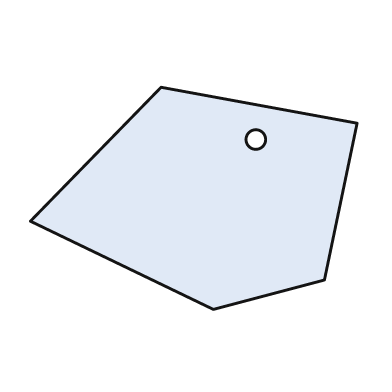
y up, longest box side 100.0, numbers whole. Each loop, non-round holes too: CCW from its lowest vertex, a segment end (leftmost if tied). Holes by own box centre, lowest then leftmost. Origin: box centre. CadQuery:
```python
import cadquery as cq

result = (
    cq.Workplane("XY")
    .moveTo(6.0, -34.0)
    .lineTo(40.0, -25.0)
    .lineTo(50.0, 23.0)
    .lineTo(-10.0, 34.0)
    .lineTo(-50.0, -7.0)
    .close()
    .moveTo(19.0, 18.0)
    .circle(3.0)
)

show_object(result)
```